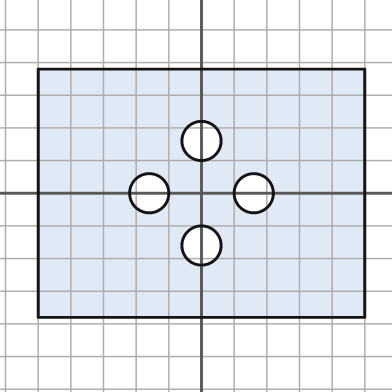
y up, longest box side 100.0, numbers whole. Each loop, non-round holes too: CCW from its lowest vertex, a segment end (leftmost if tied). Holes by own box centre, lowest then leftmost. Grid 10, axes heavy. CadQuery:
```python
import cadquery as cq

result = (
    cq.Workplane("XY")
    .moveTo(-50.0, -38.0)
    .lineTo(50.0, -38.0)
    .lineTo(50.0, 38.0)
    .lineTo(-50.0, 38.0)
    .close()
    .moveTo(0.0, -16.0)
    .circle(6.0)
    .moveTo(-16.0, 0.0)
    .circle(6.0)
    .moveTo(16.0, 0.0)
    .circle(6.0)
    .moveTo(0.0, 16.0)
    .circle(6.0)
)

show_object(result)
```